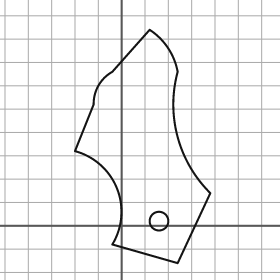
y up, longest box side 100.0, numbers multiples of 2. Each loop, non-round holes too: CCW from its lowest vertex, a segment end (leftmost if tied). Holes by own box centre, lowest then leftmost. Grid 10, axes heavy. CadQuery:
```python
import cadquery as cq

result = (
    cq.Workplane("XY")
    .moveTo(24.0, -16.0)
    .lineTo(38.0, 14.0)
    .threePointArc((24.0, 38.0), (24.0, 66.0))
    .threePointArc((20.0, 76.0), (12.0, 84.0))
    .lineTo(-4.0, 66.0)
    .threePointArc((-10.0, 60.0), (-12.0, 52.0))
    .lineTo(-20.0, 32.0)
    .threePointArc((-2.0, 16.0), (-4.0, -8.0))
    .close()
    .moveTo(16.0, 2.0)
    .circle(4.0)
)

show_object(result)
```